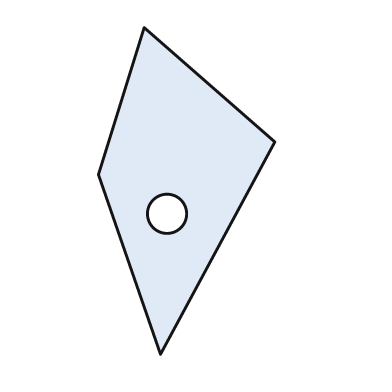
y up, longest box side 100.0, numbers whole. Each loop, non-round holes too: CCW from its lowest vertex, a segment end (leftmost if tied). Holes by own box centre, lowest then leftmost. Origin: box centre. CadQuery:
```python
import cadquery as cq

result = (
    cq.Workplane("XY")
    .moveTo(-8.0, -50.0)
    .lineTo(27.0, 15.0)
    .lineTo(-13.0, 50.0)
    .lineTo(-27.0, 5.0)
    .close()
    .moveTo(-6.0, -7.0)
    .circle(6.0)
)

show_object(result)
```